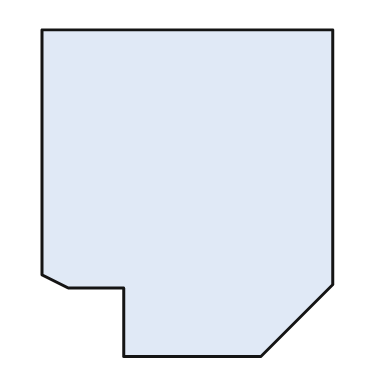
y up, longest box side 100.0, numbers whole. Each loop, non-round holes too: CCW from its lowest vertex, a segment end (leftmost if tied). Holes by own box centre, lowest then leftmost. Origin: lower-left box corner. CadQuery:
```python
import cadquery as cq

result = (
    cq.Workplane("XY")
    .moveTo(25.0, 0.0)
    .lineTo(67.0, 0.0)
    .lineTo(89.0, 22.0)
    .lineTo(89.0, 100.0)
    .lineTo(0.0, 100.0)
    .lineTo(0.0, 25.0)
    .lineTo(8.0, 21.0)
    .lineTo(25.0, 21.0)
    .close()
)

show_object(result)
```